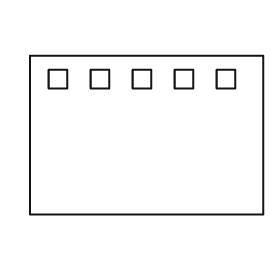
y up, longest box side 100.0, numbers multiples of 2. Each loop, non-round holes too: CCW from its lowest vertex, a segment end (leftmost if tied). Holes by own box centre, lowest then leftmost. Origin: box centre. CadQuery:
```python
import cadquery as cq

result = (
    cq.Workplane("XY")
    .moveTo(-50.0, -34.0)
    .lineTo(50.0, -34.0)
    .lineTo(50.0, 34.0)
    .lineTo(-50.0, 34.0)
    .close()
    .moveTo(-42.0, 20.0)
    .lineTo(-34.0, 20.0)
    .lineTo(-34.0, 28.0)
    .lineTo(-42.0, 28.0)
    .close()
    .moveTo(-24.0, 20.0)
    .lineTo(-16.0, 20.0)
    .lineTo(-16.0, 28.0)
    .lineTo(-24.0, 28.0)
    .close()
    .moveTo(-6.0, 20.0)
    .lineTo(2.0, 20.0)
    .lineTo(2.0, 28.0)
    .lineTo(-6.0, 28.0)
    .close()
    .moveTo(12.0, 20.0)
    .lineTo(20.0, 20.0)
    .lineTo(20.0, 28.0)
    .lineTo(12.0, 28.0)
    .close()
    .moveTo(30.0, 20.0)
    .lineTo(38.0, 20.0)
    .lineTo(38.0, 28.0)
    .lineTo(30.0, 28.0)
    .close()
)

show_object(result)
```